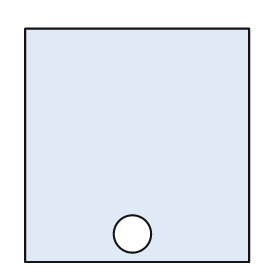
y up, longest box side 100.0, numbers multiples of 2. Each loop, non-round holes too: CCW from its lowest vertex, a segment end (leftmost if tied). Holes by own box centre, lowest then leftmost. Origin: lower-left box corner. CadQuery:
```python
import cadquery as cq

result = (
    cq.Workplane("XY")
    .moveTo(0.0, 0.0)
    .lineTo(96.0, 0.0)
    .lineTo(96.0, 100.0)
    .lineTo(0.0, 100.0)
    .close()
    .moveTo(46.0, 12.0)
    .circle(8.0)
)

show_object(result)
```